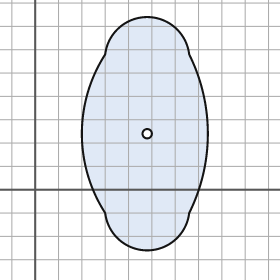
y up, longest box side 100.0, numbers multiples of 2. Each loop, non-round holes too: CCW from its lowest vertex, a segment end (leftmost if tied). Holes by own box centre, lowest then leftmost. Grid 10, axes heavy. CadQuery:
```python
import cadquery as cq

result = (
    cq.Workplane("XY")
    .moveTo(30.0, -10.0)
    .threePointArc((48.0, -26.0), (66.0, -10.0))
    .threePointArc((74.0, 24.0), (66.0, 58.0))
    .threePointArc((48.0, 74.0), (30.0, 58.0))
    .threePointArc((20.0, 24.0), (30.0, -10.0))
    .close()
    .moveTo(48.0, 24.0)
    .circle(2.0)
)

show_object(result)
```